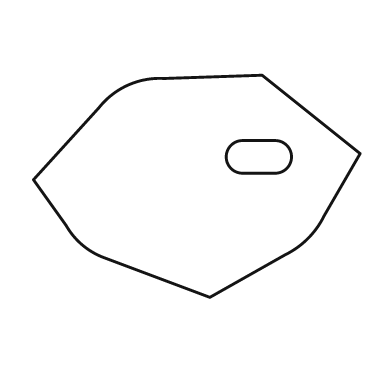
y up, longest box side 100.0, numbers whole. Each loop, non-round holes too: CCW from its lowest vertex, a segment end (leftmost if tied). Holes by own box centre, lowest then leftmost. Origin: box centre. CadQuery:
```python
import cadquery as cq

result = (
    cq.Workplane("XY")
    .moveTo(4.0, -34.0)
    .lineTo(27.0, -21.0)
    .threePointArc((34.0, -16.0), (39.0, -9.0))
    .lineTo(50.0, 10.0)
    .lineTo(20.0, 34.0)
    .lineTo(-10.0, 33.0)
    .threePointArc((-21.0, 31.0), (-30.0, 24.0))
    .lineTo(-50.0, 2.0)
    .lineTo(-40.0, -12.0)
    .threePointArc((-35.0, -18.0), (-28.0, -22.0))
    .close()
    .moveTo(14.0, 4.0)
    .lineTo(24.0, 4.0)
    .threePointArc((29.0, 9.0), (24.0, 14.0))
    .lineTo(14.0, 14.0)
    .threePointArc((9.0, 9.0), (14.0, 4.0))
    .close()
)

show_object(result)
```